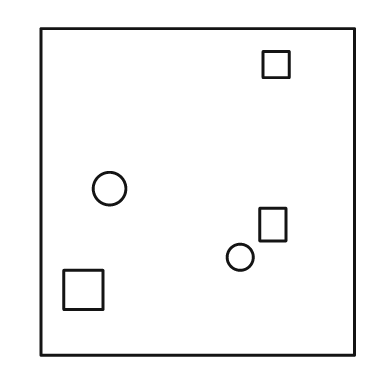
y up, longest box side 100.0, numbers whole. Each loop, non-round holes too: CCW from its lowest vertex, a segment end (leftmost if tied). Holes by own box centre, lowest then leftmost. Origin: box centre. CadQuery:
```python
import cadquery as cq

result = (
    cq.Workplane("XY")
    .moveTo(-48.0, -50.0)
    .lineTo(48.0, -50.0)
    .lineTo(48.0, 50.0)
    .lineTo(-48.0, 50.0)
    .close()
    .moveTo(-41.0, -36.0)
    .lineTo(-29.0, -36.0)
    .lineTo(-29.0, -24.0)
    .lineTo(-41.0, -24.0)
    .close()
    .moveTo(13.0, -20.0)
    .circle(4.0)
    .moveTo(19.0, -15.0)
    .lineTo(27.0, -15.0)
    .lineTo(27.0, -5.0)
    .lineTo(19.0, -5.0)
    .close()
    .moveTo(-27.0, 1.0)
    .circle(5.0)
    .moveTo(20.0, 35.0)
    .lineTo(28.0, 35.0)
    .lineTo(28.0, 43.0)
    .lineTo(20.0, 43.0)
    .close()
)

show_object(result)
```